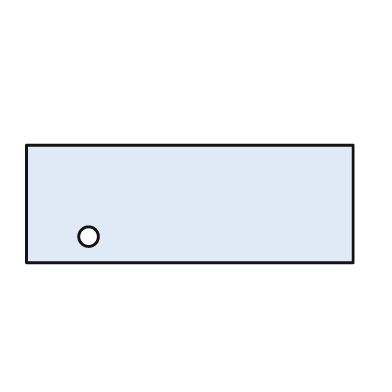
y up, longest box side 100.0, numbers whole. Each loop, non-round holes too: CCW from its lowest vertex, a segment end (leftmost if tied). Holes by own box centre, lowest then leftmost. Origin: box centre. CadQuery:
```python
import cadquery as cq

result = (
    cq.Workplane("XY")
    .moveTo(-50.0, -18.0)
    .lineTo(50.0, -18.0)
    .lineTo(50.0, 18.0)
    .lineTo(-50.0, 18.0)
    .close()
    .moveTo(-31.0, -10.0)
    .circle(3.0)
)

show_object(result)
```